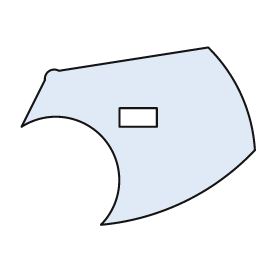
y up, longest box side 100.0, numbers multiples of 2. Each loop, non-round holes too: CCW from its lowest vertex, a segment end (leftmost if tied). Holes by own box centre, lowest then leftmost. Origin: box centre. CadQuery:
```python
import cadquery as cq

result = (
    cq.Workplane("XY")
    .moveTo(-16.0, -38.0)
    .threePointArc((20.0, -28.0), (50.0, -6.0))
    .threePointArc((44.0, 18.0), (30.0, 38.0))
    .lineTo(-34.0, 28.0)
    .threePointArc((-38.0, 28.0), (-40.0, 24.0))
    .lineTo(-50.0, 4.0)
    .threePointArc((-14.0, -2.0), (-16.0, -38.0))
    .close()
    .moveTo(-8.0, 4.0)
    .lineTo(8.0, 4.0)
    .lineTo(8.0, 12.0)
    .lineTo(-8.0, 12.0)
    .close()
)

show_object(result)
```